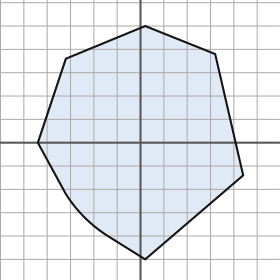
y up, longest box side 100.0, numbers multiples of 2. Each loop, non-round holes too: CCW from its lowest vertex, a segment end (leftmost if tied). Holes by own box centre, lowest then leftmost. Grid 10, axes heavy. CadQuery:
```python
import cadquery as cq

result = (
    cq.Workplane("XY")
    .moveTo(2.0, -50.0)
    .lineTo(44.0, -14.0)
    .lineTo(32.0, 38.0)
    .lineTo(2.0, 50.0)
    .lineTo(-32.0, 36.0)
    .lineTo(-44.0, 0.0)
    .lineTo(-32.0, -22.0)
    .threePointArc((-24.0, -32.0), (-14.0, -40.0))
    .close()
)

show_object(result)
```